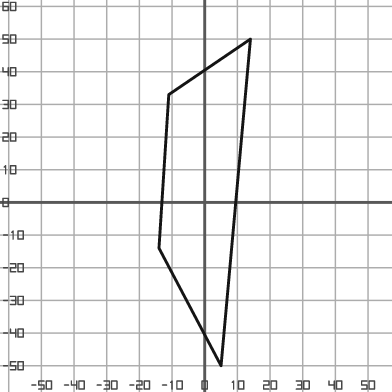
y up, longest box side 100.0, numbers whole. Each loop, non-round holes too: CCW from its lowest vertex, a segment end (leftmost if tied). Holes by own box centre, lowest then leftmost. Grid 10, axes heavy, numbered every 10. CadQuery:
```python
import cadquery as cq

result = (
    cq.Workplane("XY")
    .moveTo(5.0, -50.0)
    .lineTo(14.0, 50.0)
    .lineTo(-11.0, 33.0)
    .lineTo(-14.0, -14.0)
    .close()
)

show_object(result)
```